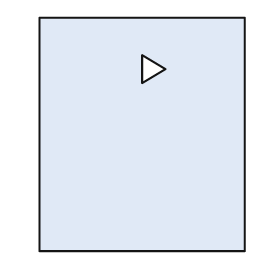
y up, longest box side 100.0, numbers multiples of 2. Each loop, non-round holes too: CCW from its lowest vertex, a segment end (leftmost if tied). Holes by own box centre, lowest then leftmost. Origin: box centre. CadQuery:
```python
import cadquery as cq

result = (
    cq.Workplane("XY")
    .moveTo(-44.0, -50.0)
    .lineTo(44.0, -50.0)
    .lineTo(44.0, 50.0)
    .lineTo(-44.0, 50.0)
    .close()
    .moveTo(0.0, 22.0)
    .lineTo(10.0, 28.0)
    .lineTo(0.0, 34.0)
    .close()
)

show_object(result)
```